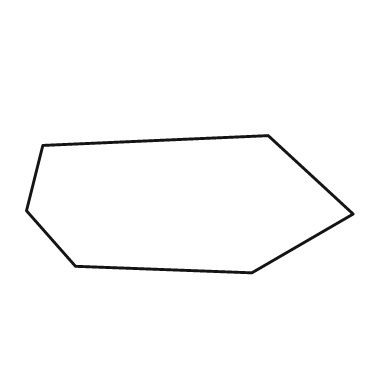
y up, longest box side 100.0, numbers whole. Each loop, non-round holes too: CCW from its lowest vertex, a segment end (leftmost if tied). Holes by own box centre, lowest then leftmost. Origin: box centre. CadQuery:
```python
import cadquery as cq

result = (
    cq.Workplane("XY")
    .moveTo(19.0, -21.0)
    .lineTo(50.0, -3.0)
    .lineTo(24.0, 21.0)
    .lineTo(-45.0, 18.0)
    .lineTo(-50.0, -2.0)
    .lineTo(-35.0, -19.0)
    .close()
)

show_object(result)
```